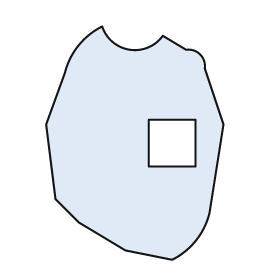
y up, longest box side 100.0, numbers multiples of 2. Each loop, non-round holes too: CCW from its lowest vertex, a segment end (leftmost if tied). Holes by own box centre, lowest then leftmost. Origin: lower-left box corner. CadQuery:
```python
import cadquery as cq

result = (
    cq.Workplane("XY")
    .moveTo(54.0, 0.0)
    .threePointArc((64.0, 8.0), (70.0, 20.0))
    .lineTo(76.0, 58.0)
    .lineTo(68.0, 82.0)
    .threePointArc((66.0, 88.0), (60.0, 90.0))
    .lineTo(50.0, 96.0)
    .threePointArc((36.0, 90.0), (24.0, 100.0))
    .threePointArc((14.0, 92.0), (8.0, 80.0))
    .lineTo(0.0, 58.0)
    .lineTo(4.0, 26.0)
    .lineTo(14.0, 16.0)
    .lineTo(34.0, 4.0)
    .close()
    .moveTo(44.0, 40.0)
    .lineTo(64.0, 40.0)
    .lineTo(64.0, 60.0)
    .lineTo(44.0, 60.0)
    .close()
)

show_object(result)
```